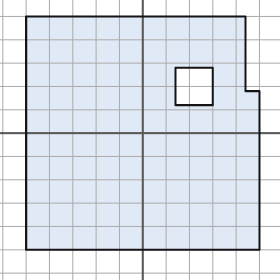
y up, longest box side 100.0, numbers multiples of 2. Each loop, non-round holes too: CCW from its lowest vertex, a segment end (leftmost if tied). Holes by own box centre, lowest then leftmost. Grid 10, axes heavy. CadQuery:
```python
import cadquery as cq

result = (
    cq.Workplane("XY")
    .moveTo(-50.0, -50.0)
    .lineTo(50.0, -50.0)
    .lineTo(50.0, 18.0)
    .lineTo(44.0, 18.0)
    .lineTo(44.0, 50.0)
    .lineTo(-50.0, 50.0)
    .close()
    .moveTo(14.0, 12.0)
    .lineTo(30.0, 12.0)
    .lineTo(30.0, 28.0)
    .lineTo(14.0, 28.0)
    .close()
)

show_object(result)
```